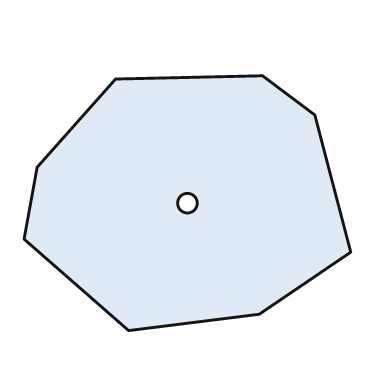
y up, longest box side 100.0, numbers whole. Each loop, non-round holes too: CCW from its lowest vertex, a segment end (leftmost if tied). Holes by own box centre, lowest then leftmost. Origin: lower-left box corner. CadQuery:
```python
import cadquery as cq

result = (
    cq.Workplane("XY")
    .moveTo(32.0, 0.0)
    .lineTo(72.0, 5.0)
    .lineTo(100.0, 24.0)
    .lineTo(89.0, 66.0)
    .lineTo(73.0, 78.0)
    .lineTo(28.0, 77.0)
    .lineTo(4.0, 50.0)
    .lineTo(0.0, 28.0)
    .close()
    .moveTo(50.0, 39.0)
    .circle(3.0)
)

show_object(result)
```